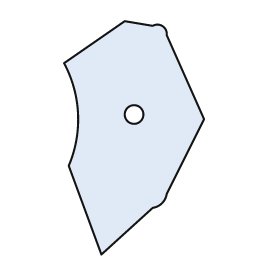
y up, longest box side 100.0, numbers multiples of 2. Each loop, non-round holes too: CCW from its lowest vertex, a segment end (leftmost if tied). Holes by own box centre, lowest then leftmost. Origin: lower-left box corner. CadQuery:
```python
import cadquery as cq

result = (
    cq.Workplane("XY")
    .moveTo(16.0, 0.0)
    .lineTo(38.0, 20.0)
    .threePointArc((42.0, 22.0), (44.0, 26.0))
    .lineTo(60.0, 58.0)
    .lineTo(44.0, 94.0)
    .threePointArc((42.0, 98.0), (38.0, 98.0))
    .lineTo(26.0, 100.0)
    .lineTo(0.0, 82.0)
    .threePointArc((6.0, 60.0), (2.0, 38.0))
    .close()
    .moveTo(30.0, 60.0)
    .circle(4.0)
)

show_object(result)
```